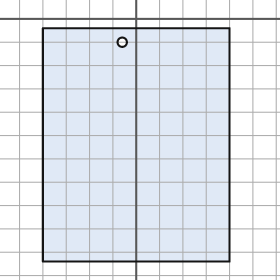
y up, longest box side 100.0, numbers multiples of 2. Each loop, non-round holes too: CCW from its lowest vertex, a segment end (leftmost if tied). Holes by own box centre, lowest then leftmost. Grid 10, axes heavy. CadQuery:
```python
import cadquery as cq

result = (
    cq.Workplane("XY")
    .moveTo(-40.0, -104.0)
    .lineTo(40.0, -104.0)
    .lineTo(40.0, -4.0)
    .lineTo(-40.0, -4.0)
    .close()
    .moveTo(-6.0, -10.0)
    .circle(2.0)
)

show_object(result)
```